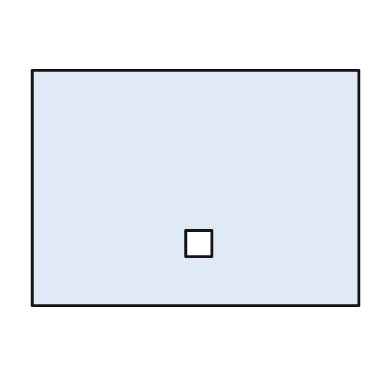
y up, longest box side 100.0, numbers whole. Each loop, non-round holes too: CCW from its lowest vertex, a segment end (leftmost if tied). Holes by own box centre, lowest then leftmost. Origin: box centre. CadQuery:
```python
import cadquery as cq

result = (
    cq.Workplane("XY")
    .moveTo(-50.0, -36.0)
    .lineTo(50.0, -36.0)
    .lineTo(50.0, 36.0)
    .lineTo(-50.0, 36.0)
    .close()
    .moveTo(-3.0, -21.0)
    .lineTo(5.0, -21.0)
    .lineTo(5.0, -13.0)
    .lineTo(-3.0, -13.0)
    .close()
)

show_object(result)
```